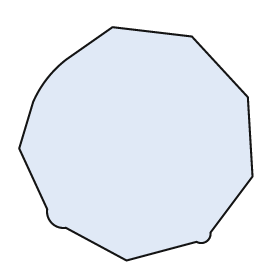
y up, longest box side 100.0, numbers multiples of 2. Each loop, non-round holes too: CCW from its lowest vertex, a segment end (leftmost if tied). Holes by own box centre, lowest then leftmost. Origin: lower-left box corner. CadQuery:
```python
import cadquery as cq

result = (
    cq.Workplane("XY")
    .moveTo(46.0, 0.0)
    .lineTo(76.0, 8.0)
    .threePointArc((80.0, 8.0), (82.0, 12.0))
    .lineTo(100.0, 36.0)
    .lineTo(98.0, 70.0)
    .lineTo(74.0, 96.0)
    .lineTo(40.0, 100.0)
    .lineTo(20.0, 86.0)
    .threePointArc((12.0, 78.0), (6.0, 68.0))
    .lineTo(0.0, 48.0)
    .lineTo(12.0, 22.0)
    .threePointArc((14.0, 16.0), (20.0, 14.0))
    .close()
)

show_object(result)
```